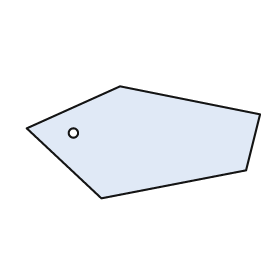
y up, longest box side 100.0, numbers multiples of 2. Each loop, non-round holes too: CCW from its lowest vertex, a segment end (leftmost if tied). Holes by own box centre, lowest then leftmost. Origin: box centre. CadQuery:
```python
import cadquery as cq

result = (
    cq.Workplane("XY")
    .moveTo(-18.0, -24.0)
    .lineTo(44.0, -12.0)
    .lineTo(50.0, 12.0)
    .lineTo(-10.0, 24.0)
    .lineTo(-50.0, 6.0)
    .close()
    .moveTo(-30.0, 4.0)
    .circle(2.0)
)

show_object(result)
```